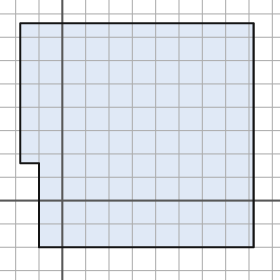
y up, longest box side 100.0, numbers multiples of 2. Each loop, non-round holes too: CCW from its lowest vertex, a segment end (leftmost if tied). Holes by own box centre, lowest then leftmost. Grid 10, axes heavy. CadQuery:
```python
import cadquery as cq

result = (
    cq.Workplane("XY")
    .moveTo(-10.0, -20.0)
    .lineTo(82.0, -20.0)
    .lineTo(82.0, 76.0)
    .lineTo(-18.0, 76.0)
    .lineTo(-18.0, 16.0)
    .lineTo(-10.0, 16.0)
    .close()
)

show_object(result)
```